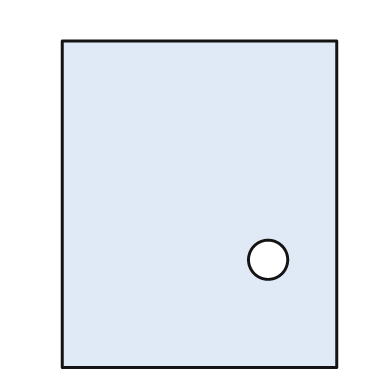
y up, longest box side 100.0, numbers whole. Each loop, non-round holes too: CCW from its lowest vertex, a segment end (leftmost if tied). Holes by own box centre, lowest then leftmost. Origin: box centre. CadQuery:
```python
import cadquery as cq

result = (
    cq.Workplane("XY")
    .moveTo(-42.0, -50.0)
    .lineTo(42.0, -50.0)
    .lineTo(42.0, 50.0)
    .lineTo(-42.0, 50.0)
    .close()
    .moveTo(21.0, -17.0)
    .circle(6.0)
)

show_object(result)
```